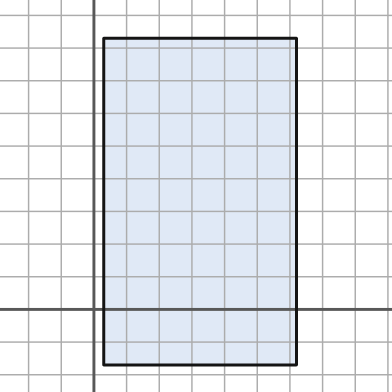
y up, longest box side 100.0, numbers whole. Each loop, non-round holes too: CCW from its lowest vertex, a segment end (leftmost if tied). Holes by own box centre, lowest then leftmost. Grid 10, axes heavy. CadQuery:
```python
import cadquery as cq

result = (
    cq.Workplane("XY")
    .moveTo(3.0, -17.0)
    .lineTo(62.0, -17.0)
    .lineTo(62.0, 83.0)
    .lineTo(3.0, 83.0)
    .close()
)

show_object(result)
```